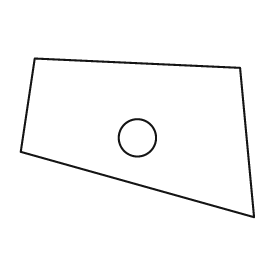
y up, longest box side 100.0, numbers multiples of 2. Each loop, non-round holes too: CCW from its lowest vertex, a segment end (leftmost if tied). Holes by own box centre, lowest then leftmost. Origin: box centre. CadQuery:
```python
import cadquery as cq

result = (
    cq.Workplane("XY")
    .moveTo(50.0, -34.0)
    .lineTo(44.0, 30.0)
    .lineTo(-44.0, 34.0)
    .lineTo(-50.0, -6.0)
    .close()
    .moveTo(0.0, 0.0)
    .circle(8.0)
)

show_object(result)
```